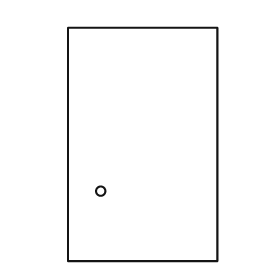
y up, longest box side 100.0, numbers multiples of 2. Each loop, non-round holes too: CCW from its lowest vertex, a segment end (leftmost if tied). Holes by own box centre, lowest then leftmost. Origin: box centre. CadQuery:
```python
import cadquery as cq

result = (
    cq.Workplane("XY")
    .moveTo(-32.0, -50.0)
    .lineTo(32.0, -50.0)
    .lineTo(32.0, 50.0)
    .lineTo(-32.0, 50.0)
    .close()
    .moveTo(-18.0, -20.0)
    .circle(2.0)
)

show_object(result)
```